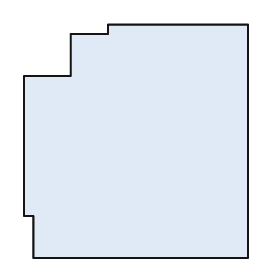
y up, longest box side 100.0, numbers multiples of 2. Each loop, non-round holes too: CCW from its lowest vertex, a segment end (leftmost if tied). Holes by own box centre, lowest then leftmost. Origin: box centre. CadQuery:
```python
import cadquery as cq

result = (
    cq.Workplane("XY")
    .moveTo(-44.0, -50.0)
    .lineTo(48.0, -50.0)
    .lineTo(48.0, 50.0)
    .lineTo(-12.0, 50.0)
    .lineTo(-12.0, 46.0)
    .lineTo(-28.0, 46.0)
    .lineTo(-28.0, 28.0)
    .lineTo(-48.0, 28.0)
    .lineTo(-48.0, -32.0)
    .lineTo(-44.0, -32.0)
    .close()
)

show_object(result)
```